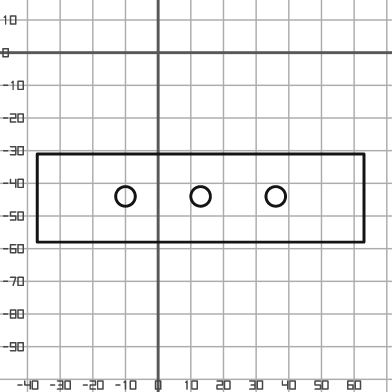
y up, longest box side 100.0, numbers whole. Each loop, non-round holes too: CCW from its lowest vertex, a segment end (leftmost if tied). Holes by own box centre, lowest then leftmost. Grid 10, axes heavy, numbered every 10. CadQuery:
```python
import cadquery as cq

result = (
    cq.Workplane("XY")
    .moveTo(-37.0, -58.0)
    .lineTo(63.0, -58.0)
    .lineTo(63.0, -31.0)
    .lineTo(-37.0, -31.0)
    .close()
    .moveTo(-10.0, -44.0)
    .circle(3.0)
    .moveTo(13.0, -44.0)
    .circle(3.0)
    .moveTo(36.0, -44.0)
    .circle(3.0)
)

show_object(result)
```